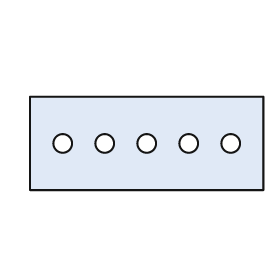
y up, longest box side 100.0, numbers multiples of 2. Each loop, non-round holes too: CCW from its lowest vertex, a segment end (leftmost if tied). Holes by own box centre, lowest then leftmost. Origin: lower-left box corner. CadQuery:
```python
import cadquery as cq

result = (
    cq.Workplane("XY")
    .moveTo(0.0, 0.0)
    .lineTo(100.0, 0.0)
    .lineTo(100.0, 40.0)
    .lineTo(0.0, 40.0)
    .close()
    .moveTo(14.0, 20.0)
    .circle(4.0)
    .moveTo(32.0, 20.0)
    .circle(4.0)
    .moveTo(50.0, 20.0)
    .circle(4.0)
    .moveTo(68.0, 20.0)
    .circle(4.0)
    .moveTo(86.0, 20.0)
    .circle(4.0)
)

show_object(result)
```